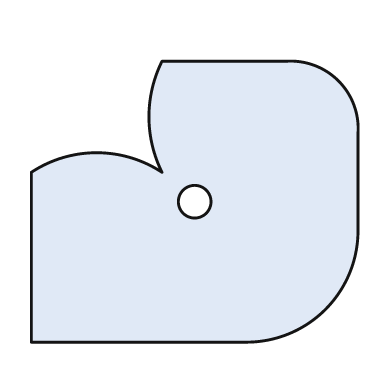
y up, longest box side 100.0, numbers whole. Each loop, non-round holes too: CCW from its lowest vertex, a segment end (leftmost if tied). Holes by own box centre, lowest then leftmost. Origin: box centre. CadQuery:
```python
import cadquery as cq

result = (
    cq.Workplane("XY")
    .moveTo(-50.0, -43.0)
    .lineTo(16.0, -43.0)
    .threePointArc((40.0, -33.0), (50.0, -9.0))
    .lineTo(50.0, 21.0)
    .threePointArc((44.0, 37.0), (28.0, 43.0))
    .lineTo(-10.0, 43.0)
    .threePointArc((-14.0, 26.0), (-10.0, 9.0))
    .threePointArc((-30.0, 15.0), (-50.0, 9.0))
    .close()
    .moveTo(0.0, 0.0)
    .circle(5.0)
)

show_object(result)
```